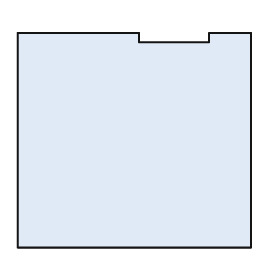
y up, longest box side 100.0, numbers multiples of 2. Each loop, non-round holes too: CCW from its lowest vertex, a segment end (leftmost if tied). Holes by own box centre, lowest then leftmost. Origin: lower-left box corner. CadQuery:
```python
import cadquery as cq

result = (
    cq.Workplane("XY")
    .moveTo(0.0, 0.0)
    .lineTo(100.0, 0.0)
    .lineTo(100.0, 92.0)
    .lineTo(82.0, 92.0)
    .lineTo(82.0, 88.0)
    .lineTo(52.0, 88.0)
    .lineTo(52.0, 92.0)
    .lineTo(0.0, 92.0)
    .close()
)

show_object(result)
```